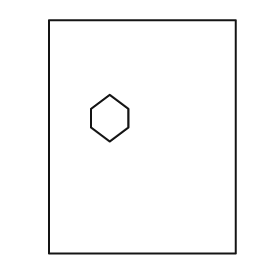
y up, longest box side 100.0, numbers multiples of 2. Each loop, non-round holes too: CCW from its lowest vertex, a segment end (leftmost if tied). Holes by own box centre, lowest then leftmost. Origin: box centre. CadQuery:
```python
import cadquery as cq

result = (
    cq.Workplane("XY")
    .moveTo(-40.0, -50.0)
    .lineTo(40.0, -50.0)
    .lineTo(40.0, 50.0)
    .lineTo(-40.0, 50.0)
    .close()
    .moveTo(-14.0, -2.0)
    .lineTo(-6.0, 4.0)
    .lineTo(-6.0, 12.0)
    .lineTo(-14.0, 18.0)
    .lineTo(-22.0, 12.0)
    .lineTo(-22.0, 4.0)
    .close()
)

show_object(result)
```